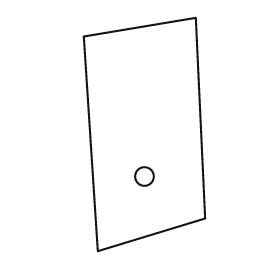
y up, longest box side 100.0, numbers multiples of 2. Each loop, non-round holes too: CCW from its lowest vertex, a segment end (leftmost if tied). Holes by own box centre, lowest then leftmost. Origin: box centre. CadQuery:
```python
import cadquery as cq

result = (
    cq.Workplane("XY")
    .moveTo(-20.0, -50.0)
    .lineTo(26.0, -36.0)
    .lineTo(22.0, 50.0)
    .lineTo(-26.0, 42.0)
    .close()
    .moveTo(0.0, -18.0)
    .circle(4.0)
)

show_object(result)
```